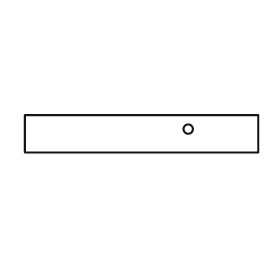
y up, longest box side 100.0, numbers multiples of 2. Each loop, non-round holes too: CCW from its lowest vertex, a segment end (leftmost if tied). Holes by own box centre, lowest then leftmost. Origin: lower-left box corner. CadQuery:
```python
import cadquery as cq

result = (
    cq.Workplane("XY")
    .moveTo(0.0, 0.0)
    .lineTo(100.0, 0.0)
    .lineTo(100.0, 16.0)
    .lineTo(0.0, 16.0)
    .close()
    .moveTo(70.0, 10.0)
    .circle(2.0)
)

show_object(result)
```